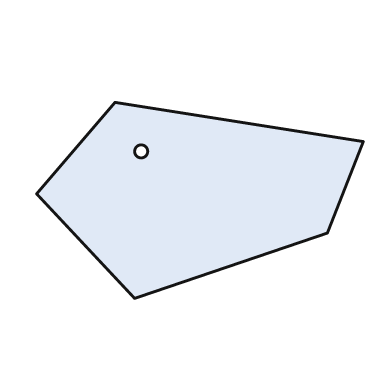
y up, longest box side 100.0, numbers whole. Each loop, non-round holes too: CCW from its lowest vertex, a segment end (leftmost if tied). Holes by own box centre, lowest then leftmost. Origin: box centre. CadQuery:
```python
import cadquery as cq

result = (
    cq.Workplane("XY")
    .moveTo(-20.0, -30.0)
    .lineTo(39.0, -10.0)
    .lineTo(50.0, 18.0)
    .lineTo(-26.0, 30.0)
    .lineTo(-50.0, 2.0)
    .close()
    .moveTo(-18.0, 15.0)
    .circle(2.0)
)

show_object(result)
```